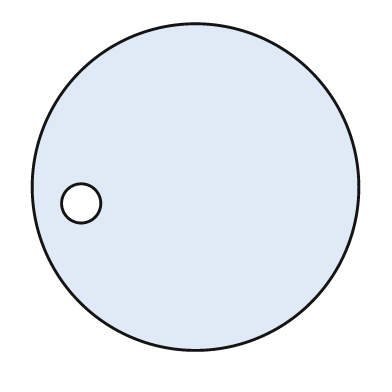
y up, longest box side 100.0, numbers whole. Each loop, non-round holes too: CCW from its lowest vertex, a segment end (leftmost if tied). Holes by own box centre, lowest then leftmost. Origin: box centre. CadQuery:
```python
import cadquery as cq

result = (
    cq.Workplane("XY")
    .moveTo(0.0, 0.0)
    .circle(50.0)
    .moveTo(-35.0, -5.0)
    .circle(6.0)
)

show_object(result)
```